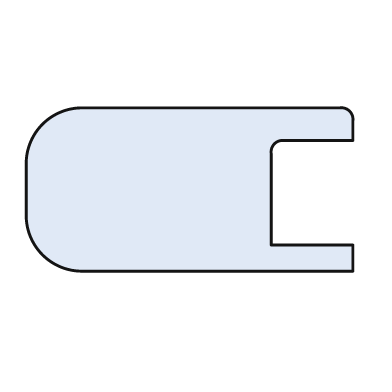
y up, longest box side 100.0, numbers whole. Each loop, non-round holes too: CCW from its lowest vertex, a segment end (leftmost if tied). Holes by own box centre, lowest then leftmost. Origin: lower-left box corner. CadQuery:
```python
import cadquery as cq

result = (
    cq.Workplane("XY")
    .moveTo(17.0, 0.0)
    .lineTo(100.0, 0.0)
    .lineTo(100.0, 8.0)
    .lineTo(75.0, 8.0)
    .lineTo(75.0, 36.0)
    .threePointArc((76.0, 39.0), (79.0, 40.0))
    .lineTo(100.0, 40.0)
    .lineTo(100.0, 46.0)
    .threePointArc((99.0, 49.0), (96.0, 50.0))
    .lineTo(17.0, 50.0)
    .threePointArc((5.0, 45.0), (0.0, 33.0))
    .lineTo(0.0, 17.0)
    .threePointArc((5.0, 5.0), (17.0, 0.0))
    .close()
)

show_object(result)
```